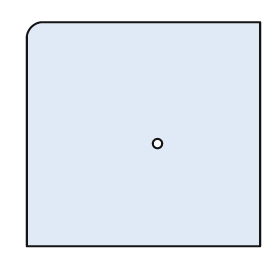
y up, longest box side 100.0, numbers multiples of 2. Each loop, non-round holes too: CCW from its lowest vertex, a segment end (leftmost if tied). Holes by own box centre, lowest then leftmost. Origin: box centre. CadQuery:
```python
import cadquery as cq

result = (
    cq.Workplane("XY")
    .moveTo(-50.0, -48.0)
    .lineTo(50.0, -48.0)
    .lineTo(50.0, 48.0)
    .lineTo(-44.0, 48.0)
    .threePointArc((-48.0, 46.0), (-50.0, 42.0))
    .close()
    .moveTo(6.0, -4.0)
    .circle(2.0)
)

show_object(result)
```